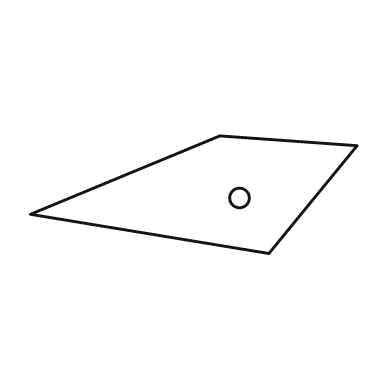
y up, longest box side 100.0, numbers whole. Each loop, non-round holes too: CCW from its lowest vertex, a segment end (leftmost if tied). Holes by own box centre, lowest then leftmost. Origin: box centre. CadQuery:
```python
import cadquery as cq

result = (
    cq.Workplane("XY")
    .moveTo(23.0, -18.0)
    .lineTo(50.0, 15.0)
    .lineTo(8.0, 18.0)
    .lineTo(-50.0, -6.0)
    .close()
    .moveTo(14.0, -1.0)
    .circle(3.0)
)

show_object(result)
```